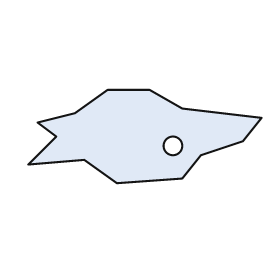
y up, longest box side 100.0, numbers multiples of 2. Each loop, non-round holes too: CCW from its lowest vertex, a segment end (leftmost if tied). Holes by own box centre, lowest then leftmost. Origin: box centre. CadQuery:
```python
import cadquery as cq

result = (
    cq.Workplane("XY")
    .moveTo(-12.0, -20.0)
    .lineTo(16.0, -18.0)
    .lineTo(24.0, -8.0)
    .lineTo(42.0, -2.0)
    .lineTo(50.0, 8.0)
    .lineTo(16.0, 12.0)
    .lineTo(2.0, 20.0)
    .lineTo(-16.0, 20.0)
    .lineTo(-30.0, 10.0)
    .lineTo(-46.0, 6.0)
    .lineTo(-38.0, 0.0)
    .lineTo(-50.0, -12.0)
    .lineTo(-26.0, -10.0)
    .close()
    .moveTo(12.0, -4.0)
    .circle(4.0)
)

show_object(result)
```